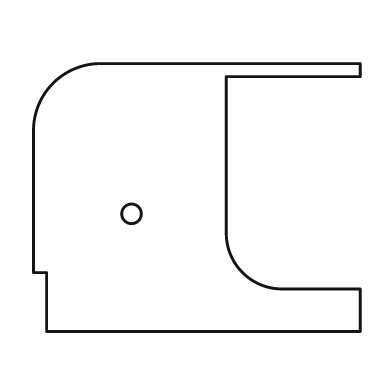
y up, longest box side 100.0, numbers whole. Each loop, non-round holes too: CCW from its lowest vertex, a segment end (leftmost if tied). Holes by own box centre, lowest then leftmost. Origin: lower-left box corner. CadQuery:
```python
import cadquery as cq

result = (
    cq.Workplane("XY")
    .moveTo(4.0, 0.0)
    .lineTo(100.0, 0.0)
    .lineTo(100.0, 13.0)
    .lineTo(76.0, 13.0)
    .threePointArc((64.0, 18.0), (59.0, 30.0))
    .lineTo(59.0, 78.0)
    .lineTo(100.0, 78.0)
    .lineTo(100.0, 82.0)
    .lineTo(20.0, 82.0)
    .threePointArc((6.0, 76.0), (0.0, 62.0))
    .lineTo(0.0, 18.0)
    .lineTo(4.0, 18.0)
    .close()
    .moveTo(30.0, 36.0)
    .circle(3.0)
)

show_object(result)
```